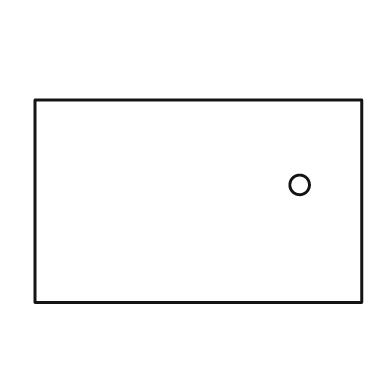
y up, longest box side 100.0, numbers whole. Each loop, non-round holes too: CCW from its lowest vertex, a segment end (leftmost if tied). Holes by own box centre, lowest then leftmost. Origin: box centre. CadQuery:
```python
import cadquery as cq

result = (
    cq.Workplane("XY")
    .moveTo(-50.0, -31.0)
    .lineTo(50.0, -31.0)
    .lineTo(50.0, 31.0)
    .lineTo(-50.0, 31.0)
    .close()
    .moveTo(31.0, 5.0)
    .circle(3.0)
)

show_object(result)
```